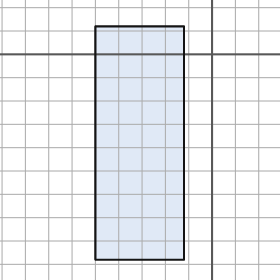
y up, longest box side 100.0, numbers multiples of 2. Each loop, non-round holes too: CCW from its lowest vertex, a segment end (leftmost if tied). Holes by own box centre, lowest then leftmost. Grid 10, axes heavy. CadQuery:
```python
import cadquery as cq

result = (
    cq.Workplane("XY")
    .moveTo(-50.0, -88.0)
    .lineTo(-12.0, -88.0)
    .lineTo(-12.0, 12.0)
    .lineTo(-50.0, 12.0)
    .close()
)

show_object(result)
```